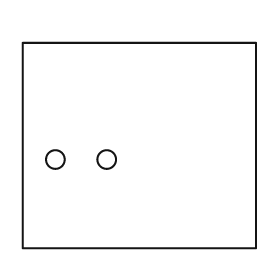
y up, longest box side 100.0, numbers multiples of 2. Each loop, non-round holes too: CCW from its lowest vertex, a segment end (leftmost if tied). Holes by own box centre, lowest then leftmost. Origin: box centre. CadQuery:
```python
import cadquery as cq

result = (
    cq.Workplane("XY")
    .moveTo(-50.0, -44.0)
    .lineTo(50.0, -44.0)
    .lineTo(50.0, 44.0)
    .lineTo(-50.0, 44.0)
    .close()
    .moveTo(-36.0, -6.0)
    .circle(4.0)
    .moveTo(-14.0, -6.0)
    .circle(4.0)
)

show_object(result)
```